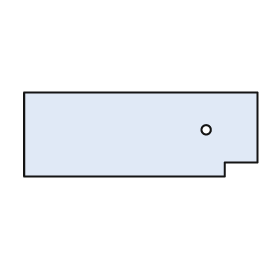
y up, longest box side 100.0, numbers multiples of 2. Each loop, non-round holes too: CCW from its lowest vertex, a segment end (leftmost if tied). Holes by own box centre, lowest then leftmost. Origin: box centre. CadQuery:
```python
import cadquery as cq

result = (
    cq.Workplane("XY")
    .moveTo(-50.0, -18.0)
    .lineTo(36.0, -18.0)
    .lineTo(36.0, -12.0)
    .lineTo(50.0, -12.0)
    .lineTo(50.0, 18.0)
    .lineTo(-50.0, 18.0)
    .close()
    .moveTo(28.0, 2.0)
    .circle(2.0)
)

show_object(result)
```